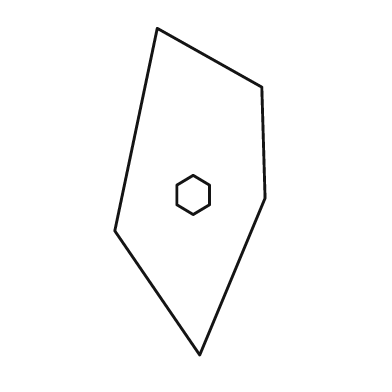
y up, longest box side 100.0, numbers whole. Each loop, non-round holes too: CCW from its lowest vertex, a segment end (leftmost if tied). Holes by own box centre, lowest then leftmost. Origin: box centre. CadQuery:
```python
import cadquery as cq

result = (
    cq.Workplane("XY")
    .moveTo(3.0, -50.0)
    .lineTo(23.0, -2.0)
    .lineTo(22.0, 32.0)
    .lineTo(-10.0, 50.0)
    .lineTo(-23.0, -12.0)
    .close()
    .moveTo(1.0, -7.0)
    .lineTo(6.0, -4.0)
    .lineTo(6.0, 2.0)
    .lineTo(1.0, 5.0)
    .lineTo(-4.0, 2.0)
    .lineTo(-4.0, -4.0)
    .close()
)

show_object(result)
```